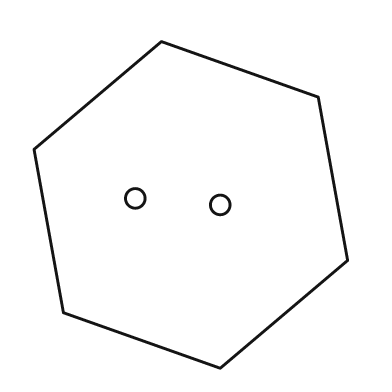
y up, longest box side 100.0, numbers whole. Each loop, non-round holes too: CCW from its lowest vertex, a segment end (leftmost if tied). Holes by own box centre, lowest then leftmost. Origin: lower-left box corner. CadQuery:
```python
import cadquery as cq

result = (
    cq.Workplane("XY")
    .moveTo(57.0, 0.0)
    .lineTo(96.0, 33.0)
    .lineTo(87.0, 83.0)
    .lineTo(39.0, 100.0)
    .lineTo(0.0, 67.0)
    .lineTo(9.0, 17.0)
    .close()
    .moveTo(57.0, 50.0)
    .circle(3.0)
    .moveTo(31.0, 52.0)
    .circle(3.0)
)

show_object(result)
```